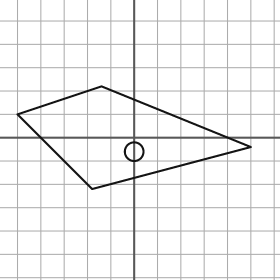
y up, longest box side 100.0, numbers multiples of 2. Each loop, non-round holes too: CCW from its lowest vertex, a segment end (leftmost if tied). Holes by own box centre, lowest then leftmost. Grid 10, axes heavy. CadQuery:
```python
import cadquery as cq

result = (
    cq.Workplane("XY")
    .moveTo(-18.0, -22.0)
    .lineTo(50.0, -4.0)
    .lineTo(-14.0, 22.0)
    .lineTo(-50.0, 10.0)
    .close()
    .moveTo(0.0, -6.0)
    .circle(4.0)
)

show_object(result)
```